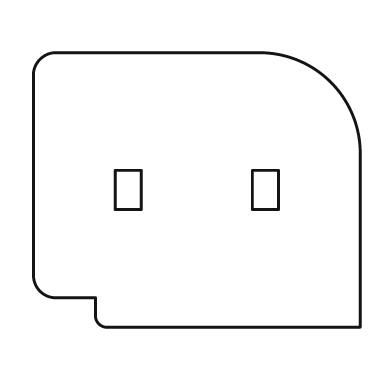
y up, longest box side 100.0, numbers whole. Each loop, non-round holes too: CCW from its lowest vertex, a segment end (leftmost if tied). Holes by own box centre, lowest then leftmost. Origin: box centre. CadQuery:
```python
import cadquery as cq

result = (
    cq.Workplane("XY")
    .moveTo(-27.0, -42.0)
    .lineTo(50.0, -42.0)
    .lineTo(50.0, 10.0)
    .threePointArc((41.0, 33.0), (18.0, 42.0))
    .lineTo(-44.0, 42.0)
    .threePointArc((-48.0, 40.0), (-50.0, 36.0))
    .lineTo(-50.0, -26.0)
    .threePointArc((-48.0, -31.0), (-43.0, -33.0))
    .lineTo(-31.0, -33.0)
    .lineTo(-31.0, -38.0)
    .threePointArc((-30.0, -41.0), (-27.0, -42.0))
    .close()
    .moveTo(-25.0, -6.0)
    .lineTo(-17.0, -6.0)
    .lineTo(-17.0, 6.0)
    .lineTo(-25.0, 6.0)
    .close()
    .moveTo(17.0, -6.0)
    .lineTo(25.0, -6.0)
    .lineTo(25.0, 6.0)
    .lineTo(17.0, 6.0)
    .close()
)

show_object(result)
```